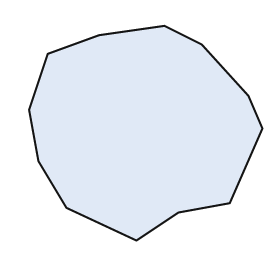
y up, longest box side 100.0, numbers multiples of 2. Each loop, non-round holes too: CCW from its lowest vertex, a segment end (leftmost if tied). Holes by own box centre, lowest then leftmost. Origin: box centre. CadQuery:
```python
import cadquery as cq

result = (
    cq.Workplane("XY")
    .moveTo(-4.0, -46.0)
    .lineTo(14.0, -34.0)
    .lineTo(36.0, -30.0)
    .lineTo(50.0, 2.0)
    .lineTo(44.0, 16.0)
    .lineTo(24.0, 38.0)
    .lineTo(8.0, 46.0)
    .lineTo(-20.0, 42.0)
    .lineTo(-42.0, 34.0)
    .lineTo(-50.0, 10.0)
    .lineTo(-46.0, -12.0)
    .lineTo(-34.0, -32.0)
    .close()
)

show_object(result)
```